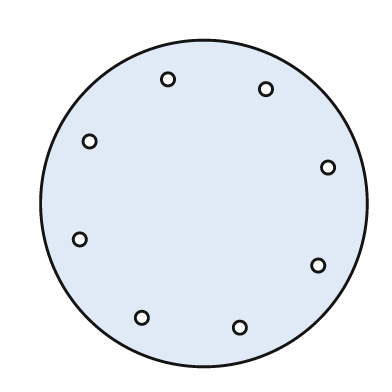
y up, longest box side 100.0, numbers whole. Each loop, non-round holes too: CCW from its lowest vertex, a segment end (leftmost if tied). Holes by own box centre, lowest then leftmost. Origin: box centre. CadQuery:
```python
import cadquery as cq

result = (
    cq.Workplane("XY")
    .moveTo(0.0, 0.0)
    .circle(50.0)
    .moveTo(11.0, -38.0)
    .circle(2.0)
    .moveTo(-19.0, -35.0)
    .circle(2.0)
    .moveTo(35.0, -19.0)
    .circle(2.0)
    .moveTo(-38.0, -11.0)
    .circle(2.0)
    .moveTo(38.0, 11.0)
    .circle(2.0)
    .moveTo(-35.0, 19.0)
    .circle(2.0)
    .moveTo(19.0, 35.0)
    .circle(2.0)
    .moveTo(-11.0, 38.0)
    .circle(2.0)
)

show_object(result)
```